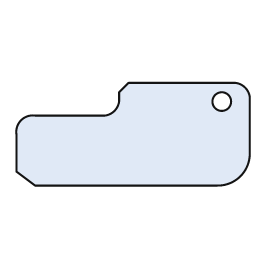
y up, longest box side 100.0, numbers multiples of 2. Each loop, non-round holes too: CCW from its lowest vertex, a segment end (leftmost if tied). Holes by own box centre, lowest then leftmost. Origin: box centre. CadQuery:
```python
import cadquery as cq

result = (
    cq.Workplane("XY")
    .moveTo(-42.0, -22.0)
    .lineTo(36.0, -22.0)
    .threePointArc((46.0, -18.0), (50.0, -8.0))
    .lineTo(50.0, 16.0)
    .threePointArc((48.0, 20.0), (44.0, 22.0))
    .lineTo(-2.0, 22.0)
    .lineTo(-6.0, 18.0)
    .lineTo(-6.0, 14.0)
    .threePointArc((-8.0, 10.0), (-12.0, 8.0))
    .lineTo(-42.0, 8.0)
    .threePointArc((-48.0, 6.0), (-50.0, 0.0))
    .lineTo(-50.0, -16.0)
    .close()
    .moveTo(38.0, 14.0)
    .circle(4.0)
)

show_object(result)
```